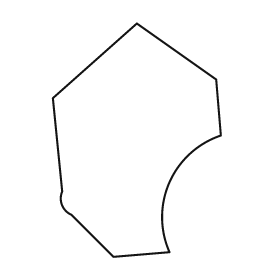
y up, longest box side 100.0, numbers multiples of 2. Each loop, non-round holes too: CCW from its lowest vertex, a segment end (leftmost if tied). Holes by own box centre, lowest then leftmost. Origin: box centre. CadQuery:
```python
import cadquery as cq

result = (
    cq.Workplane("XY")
    .moveTo(-10.0, -50.0)
    .lineTo(14.0, -48.0)
    .threePointArc((14.0, -18.0), (36.0, 2.0))
    .lineTo(34.0, 26.0)
    .lineTo(0.0, 50.0)
    .lineTo(-36.0, 18.0)
    .lineTo(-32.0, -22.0)
    .threePointArc((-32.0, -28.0), (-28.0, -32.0))
    .close()
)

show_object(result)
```